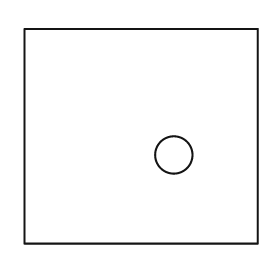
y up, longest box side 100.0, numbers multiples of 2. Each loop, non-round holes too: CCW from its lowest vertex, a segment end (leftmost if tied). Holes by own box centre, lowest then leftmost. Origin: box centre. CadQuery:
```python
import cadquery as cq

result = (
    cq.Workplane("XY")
    .moveTo(-50.0, -46.0)
    .lineTo(50.0, -46.0)
    .lineTo(50.0, 46.0)
    .lineTo(-50.0, 46.0)
    .close()
    .moveTo(14.0, -8.0)
    .circle(8.0)
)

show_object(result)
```